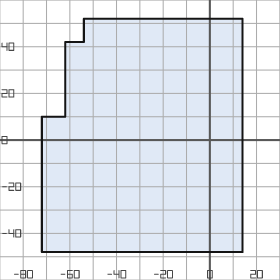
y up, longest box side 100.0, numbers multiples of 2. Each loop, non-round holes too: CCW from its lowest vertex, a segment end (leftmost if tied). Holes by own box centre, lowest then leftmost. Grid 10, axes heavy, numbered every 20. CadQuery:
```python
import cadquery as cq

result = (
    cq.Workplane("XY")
    .moveTo(-72.0, -48.0)
    .lineTo(14.0, -48.0)
    .lineTo(14.0, 52.0)
    .lineTo(-54.0, 52.0)
    .lineTo(-54.0, 42.0)
    .lineTo(-62.0, 42.0)
    .lineTo(-62.0, 10.0)
    .lineTo(-72.0, 10.0)
    .close()
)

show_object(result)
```